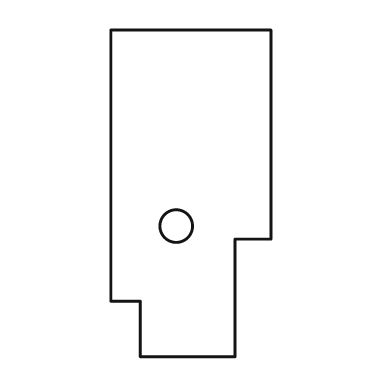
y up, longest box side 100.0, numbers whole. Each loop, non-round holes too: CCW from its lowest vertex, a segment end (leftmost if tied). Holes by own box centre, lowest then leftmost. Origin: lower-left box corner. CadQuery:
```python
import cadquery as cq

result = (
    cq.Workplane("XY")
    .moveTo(9.0, 0.0)
    .lineTo(38.0, 0.0)
    .lineTo(38.0, 36.0)
    .lineTo(49.0, 36.0)
    .lineTo(49.0, 100.0)
    .lineTo(0.0, 100.0)
    .lineTo(0.0, 17.0)
    .lineTo(9.0, 17.0)
    .close()
    .moveTo(20.0, 40.0)
    .circle(5.0)
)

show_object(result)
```